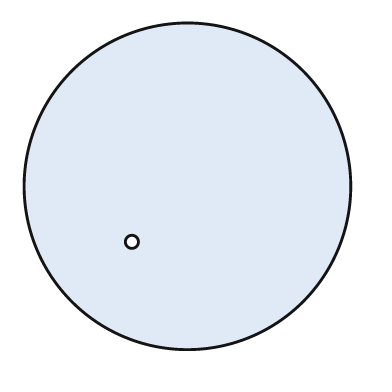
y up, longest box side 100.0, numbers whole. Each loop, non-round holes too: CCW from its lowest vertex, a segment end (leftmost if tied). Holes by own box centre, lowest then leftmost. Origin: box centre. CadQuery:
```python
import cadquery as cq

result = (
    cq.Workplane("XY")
    .moveTo(0.0, 0.0)
    .circle(50.0)
    .moveTo(-17.0, -17.0)
    .circle(2.0)
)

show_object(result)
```